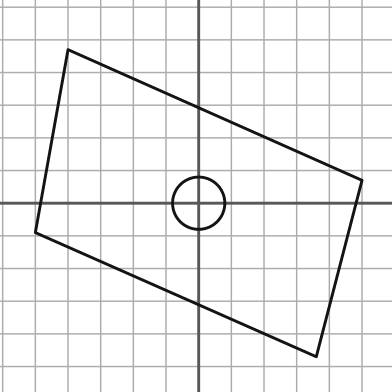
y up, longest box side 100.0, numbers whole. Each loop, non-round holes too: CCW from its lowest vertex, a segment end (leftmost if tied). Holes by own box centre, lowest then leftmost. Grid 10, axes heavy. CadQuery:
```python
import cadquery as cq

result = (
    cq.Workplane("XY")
    .moveTo(36.0, -47.0)
    .lineTo(50.0, 7.0)
    .lineTo(-40.0, 47.0)
    .lineTo(-50.0, -9.0)
    .close()
    .moveTo(0.0, 0.0)
    .circle(8.0)
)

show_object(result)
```